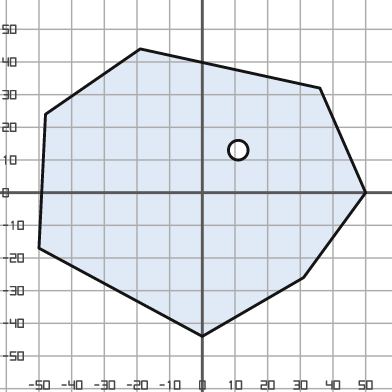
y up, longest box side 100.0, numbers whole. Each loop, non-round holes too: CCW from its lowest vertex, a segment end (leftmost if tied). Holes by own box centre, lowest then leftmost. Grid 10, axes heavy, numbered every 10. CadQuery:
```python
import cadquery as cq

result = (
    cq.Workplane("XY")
    .moveTo(0.0, -44.0)
    .lineTo(31.0, -26.0)
    .lineTo(50.0, 0.0)
    .lineTo(36.0, 32.0)
    .lineTo(-19.0, 44.0)
    .lineTo(-48.0, 24.0)
    .lineTo(-50.0, -17.0)
    .close()
    .moveTo(11.0, 13.0)
    .circle(3.0)
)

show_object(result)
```